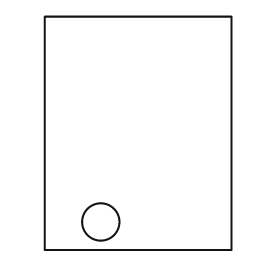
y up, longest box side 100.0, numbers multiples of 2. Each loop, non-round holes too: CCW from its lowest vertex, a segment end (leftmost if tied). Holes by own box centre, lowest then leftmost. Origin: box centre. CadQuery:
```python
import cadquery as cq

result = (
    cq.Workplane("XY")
    .moveTo(-40.0, -50.0)
    .lineTo(40.0, -50.0)
    .lineTo(40.0, 50.0)
    .lineTo(-40.0, 50.0)
    .close()
    .moveTo(-16.0, -38.0)
    .circle(8.0)
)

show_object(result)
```